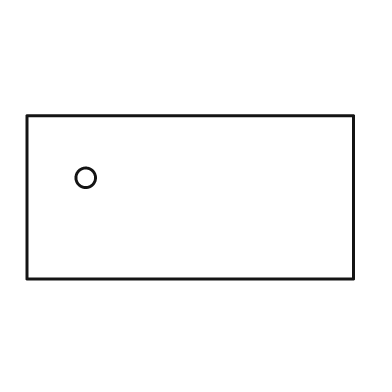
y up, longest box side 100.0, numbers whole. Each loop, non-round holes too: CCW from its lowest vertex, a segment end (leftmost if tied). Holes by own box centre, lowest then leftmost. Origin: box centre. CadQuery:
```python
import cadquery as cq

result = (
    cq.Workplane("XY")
    .moveTo(-50.0, -25.0)
    .lineTo(50.0, -25.0)
    .lineTo(50.0, 25.0)
    .lineTo(-50.0, 25.0)
    .close()
    .moveTo(-32.0, 6.0)
    .circle(3.0)
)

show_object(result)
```